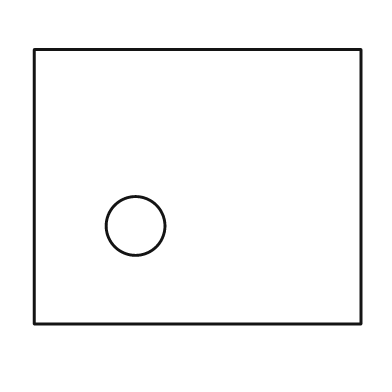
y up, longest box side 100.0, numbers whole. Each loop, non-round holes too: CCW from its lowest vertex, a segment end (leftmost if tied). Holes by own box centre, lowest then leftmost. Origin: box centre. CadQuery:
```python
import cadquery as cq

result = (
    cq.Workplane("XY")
    .moveTo(-50.0, -42.0)
    .lineTo(50.0, -42.0)
    .lineTo(50.0, 42.0)
    .lineTo(-50.0, 42.0)
    .close()
    .moveTo(-19.0, -12.0)
    .circle(9.0)
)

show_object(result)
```